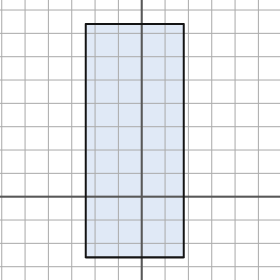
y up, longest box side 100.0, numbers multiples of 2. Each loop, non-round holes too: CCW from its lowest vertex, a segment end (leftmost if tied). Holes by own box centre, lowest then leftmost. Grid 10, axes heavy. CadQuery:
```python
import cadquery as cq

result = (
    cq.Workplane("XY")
    .moveTo(-24.0, -26.0)
    .lineTo(18.0, -26.0)
    .lineTo(18.0, 74.0)
    .lineTo(-24.0, 74.0)
    .close()
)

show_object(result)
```